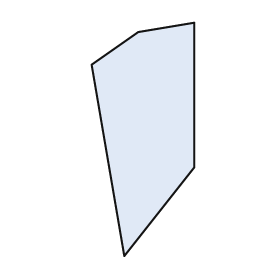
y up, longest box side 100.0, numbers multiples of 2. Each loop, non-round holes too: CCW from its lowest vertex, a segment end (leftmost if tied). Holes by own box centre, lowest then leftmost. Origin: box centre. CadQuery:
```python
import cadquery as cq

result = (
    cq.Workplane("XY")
    .moveTo(-8.0, -50.0)
    .lineTo(22.0, -12.0)
    .lineTo(22.0, 50.0)
    .lineTo(-2.0, 46.0)
    .lineTo(-22.0, 32.0)
    .close()
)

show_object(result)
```